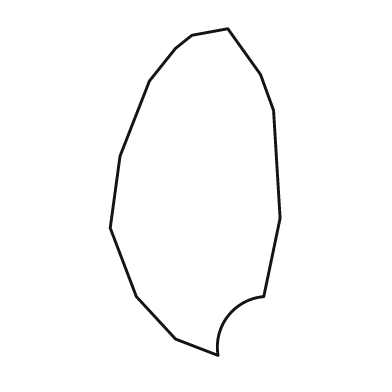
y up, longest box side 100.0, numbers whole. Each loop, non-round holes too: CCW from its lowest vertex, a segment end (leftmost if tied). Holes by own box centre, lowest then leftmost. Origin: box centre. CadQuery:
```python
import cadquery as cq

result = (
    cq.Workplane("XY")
    .moveTo(7.0, -50.0)
    .threePointArc((10.0, -38.0), (21.0, -32.0))
    .lineTo(26.0, -8.0)
    .lineTo(24.0, 25.0)
    .lineTo(20.0, 36.0)
    .lineTo(10.0, 50.0)
    .lineTo(-1.0, 48.0)
    .lineTo(-6.0, 44.0)
    .lineTo(-14.0, 34.0)
    .lineTo(-23.0, 11.0)
    .lineTo(-26.0, -11.0)
    .lineTo(-18.0, -32.0)
    .lineTo(-6.0, -45.0)
    .close()
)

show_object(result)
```